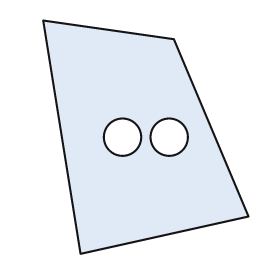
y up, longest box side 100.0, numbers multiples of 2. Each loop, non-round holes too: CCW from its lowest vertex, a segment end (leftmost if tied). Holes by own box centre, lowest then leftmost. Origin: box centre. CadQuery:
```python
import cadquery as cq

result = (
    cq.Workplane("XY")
    .moveTo(-28.0, -50.0)
    .lineTo(44.0, -34.0)
    .lineTo(12.0, 42.0)
    .lineTo(-44.0, 50.0)
    .close()
    .moveTo(-10.0, 0.0)
    .circle(8.0)
    .moveTo(10.0, 0.0)
    .circle(8.0)
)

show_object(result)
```